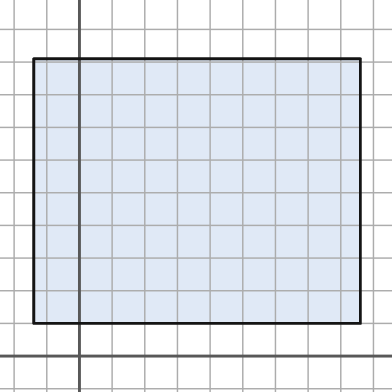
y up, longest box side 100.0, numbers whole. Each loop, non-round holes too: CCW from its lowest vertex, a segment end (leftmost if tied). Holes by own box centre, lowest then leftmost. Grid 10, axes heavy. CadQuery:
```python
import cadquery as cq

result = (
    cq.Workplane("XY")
    .moveTo(-14.0, 10.0)
    .lineTo(86.0, 10.0)
    .lineTo(86.0, 91.0)
    .lineTo(-14.0, 91.0)
    .close()
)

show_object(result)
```